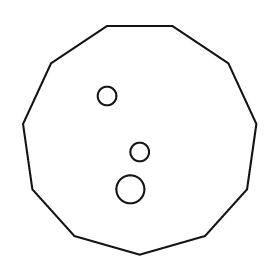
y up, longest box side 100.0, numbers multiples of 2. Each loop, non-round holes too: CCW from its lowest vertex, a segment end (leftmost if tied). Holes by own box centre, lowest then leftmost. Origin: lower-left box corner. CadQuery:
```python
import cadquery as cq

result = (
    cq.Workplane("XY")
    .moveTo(50.0, 0.0)
    .lineTo(78.0, 8.0)
    .lineTo(96.0, 28.0)
    .lineTo(100.0, 56.0)
    .lineTo(88.0, 82.0)
    .lineTo(64.0, 98.0)
    .lineTo(36.0, 98.0)
    .lineTo(12.0, 82.0)
    .lineTo(0.0, 56.0)
    .lineTo(4.0, 28.0)
    .lineTo(22.0, 8.0)
    .close()
    .moveTo(46.0, 28.0)
    .circle(6.0)
    .moveTo(50.0, 44.0)
    .circle(4.0)
    .moveTo(36.0, 68.0)
    .circle(4.0)
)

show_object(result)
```